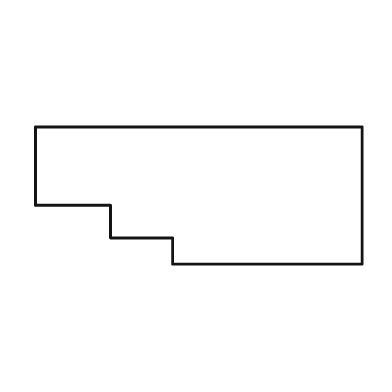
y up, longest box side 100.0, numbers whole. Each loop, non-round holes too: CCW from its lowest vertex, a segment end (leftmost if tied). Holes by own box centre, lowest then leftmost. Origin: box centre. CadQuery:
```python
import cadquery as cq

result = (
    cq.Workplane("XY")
    .moveTo(-8.0, -21.0)
    .lineTo(50.0, -21.0)
    .lineTo(50.0, 21.0)
    .lineTo(-50.0, 21.0)
    .lineTo(-50.0, -3.0)
    .lineTo(-27.0, -3.0)
    .lineTo(-27.0, -13.0)
    .lineTo(-8.0, -13.0)
    .close()
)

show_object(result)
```